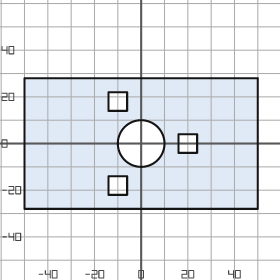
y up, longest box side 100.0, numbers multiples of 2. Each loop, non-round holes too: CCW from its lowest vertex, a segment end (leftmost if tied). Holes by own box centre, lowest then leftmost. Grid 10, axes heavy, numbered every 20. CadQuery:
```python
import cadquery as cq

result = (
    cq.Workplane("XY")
    .moveTo(-50.0, -28.0)
    .lineTo(50.0, -28.0)
    .lineTo(50.0, 28.0)
    .lineTo(-50.0, 28.0)
    .close()
    .moveTo(-14.0, -22.0)
    .lineTo(-6.0, -22.0)
    .lineTo(-6.0, -14.0)
    .lineTo(-14.0, -14.0)
    .close()
    .moveTo(0.0, 0.0)
    .circle(10.0)
    .moveTo(16.0, -4.0)
    .lineTo(24.0, -4.0)
    .lineTo(24.0, 4.0)
    .lineTo(16.0, 4.0)
    .close()
    .moveTo(-14.0, 14.0)
    .lineTo(-6.0, 14.0)
    .lineTo(-6.0, 22.0)
    .lineTo(-14.0, 22.0)
    .close()
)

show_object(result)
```